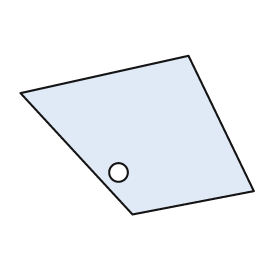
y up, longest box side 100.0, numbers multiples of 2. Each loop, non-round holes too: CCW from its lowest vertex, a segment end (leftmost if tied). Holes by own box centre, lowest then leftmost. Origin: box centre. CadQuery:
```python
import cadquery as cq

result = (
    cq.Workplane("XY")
    .moveTo(-2.0, -34.0)
    .lineTo(50.0, -24.0)
    .lineTo(22.0, 34.0)
    .lineTo(-50.0, 18.0)
    .close()
    .moveTo(-8.0, -16.0)
    .circle(4.0)
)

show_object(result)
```